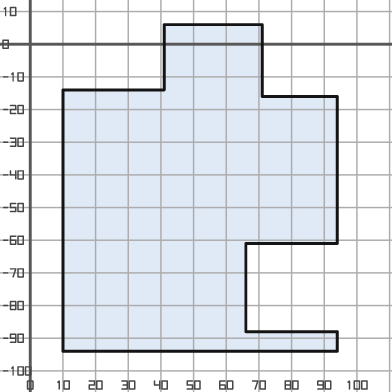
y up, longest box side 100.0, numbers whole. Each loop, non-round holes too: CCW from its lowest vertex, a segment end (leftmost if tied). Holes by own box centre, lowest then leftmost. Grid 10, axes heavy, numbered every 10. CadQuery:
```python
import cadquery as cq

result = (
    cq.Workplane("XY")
    .moveTo(10.0, -94.0)
    .lineTo(94.0, -94.0)
    .lineTo(94.0, -88.0)
    .lineTo(66.0, -88.0)
    .lineTo(66.0, -61.0)
    .lineTo(94.0, -61.0)
    .lineTo(94.0, -16.0)
    .lineTo(71.0, -16.0)
    .lineTo(71.0, 6.0)
    .lineTo(41.0, 6.0)
    .lineTo(41.0, -14.0)
    .lineTo(10.0, -14.0)
    .close()
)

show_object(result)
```